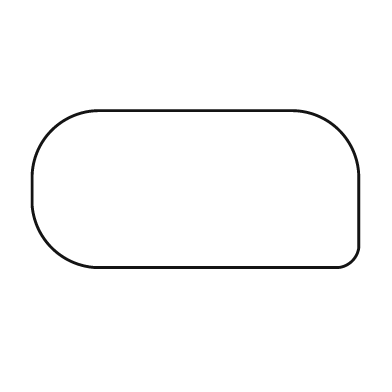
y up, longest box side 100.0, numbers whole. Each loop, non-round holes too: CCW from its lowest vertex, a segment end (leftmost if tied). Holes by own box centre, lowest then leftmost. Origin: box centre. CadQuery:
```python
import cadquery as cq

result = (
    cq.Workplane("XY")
    .moveTo(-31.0, -24.0)
    .lineTo(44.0, -24.0)
    .threePointArc((48.0, -22.0), (50.0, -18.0))
    .lineTo(50.0, 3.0)
    .threePointArc((44.0, 18.0), (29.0, 24.0))
    .lineTo(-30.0, 24.0)
    .threePointArc((-44.0, 18.0), (-50.0, 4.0))
    .lineTo(-50.0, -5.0)
    .threePointArc((-44.0, -18.0), (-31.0, -24.0))
    .close()
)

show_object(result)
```